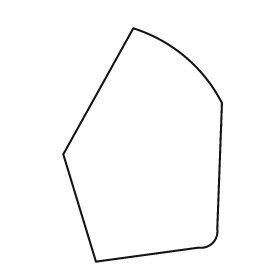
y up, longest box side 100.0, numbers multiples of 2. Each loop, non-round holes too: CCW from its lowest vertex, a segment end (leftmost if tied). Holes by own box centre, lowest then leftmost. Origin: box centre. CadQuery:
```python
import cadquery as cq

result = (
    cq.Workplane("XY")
    .moveTo(-20.0, -50.0)
    .lineTo(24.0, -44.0)
    .threePointArc((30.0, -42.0), (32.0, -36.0))
    .lineTo(34.0, 18.0)
    .threePointArc((18.0, 38.0), (-4.0, 50.0))
    .lineTo(-34.0, -4.0)
    .close()
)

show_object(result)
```